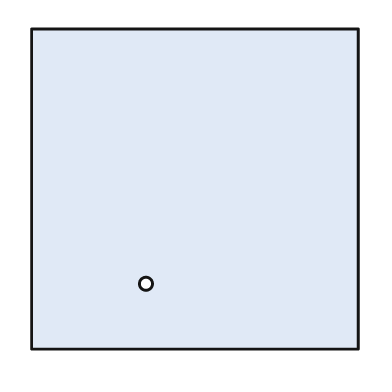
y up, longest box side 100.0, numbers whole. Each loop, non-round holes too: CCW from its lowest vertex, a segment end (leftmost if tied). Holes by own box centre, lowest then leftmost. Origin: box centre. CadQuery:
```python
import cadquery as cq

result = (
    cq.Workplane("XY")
    .moveTo(-50.0, -49.0)
    .lineTo(50.0, -49.0)
    .lineTo(50.0, 49.0)
    .lineTo(-50.0, 49.0)
    .close()
    .moveTo(-15.0, -29.0)
    .circle(2.0)
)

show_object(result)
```